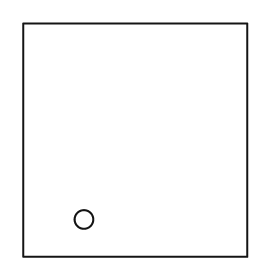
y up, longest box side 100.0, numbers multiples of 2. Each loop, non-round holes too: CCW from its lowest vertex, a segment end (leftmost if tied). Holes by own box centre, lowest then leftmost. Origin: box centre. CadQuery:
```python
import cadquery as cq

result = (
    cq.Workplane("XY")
    .moveTo(-48.0, -50.0)
    .lineTo(48.0, -50.0)
    .lineTo(48.0, 50.0)
    .lineTo(-48.0, 50.0)
    .close()
    .moveTo(-22.0, -34.0)
    .circle(4.0)
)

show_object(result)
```